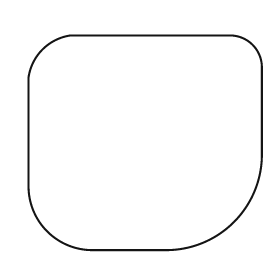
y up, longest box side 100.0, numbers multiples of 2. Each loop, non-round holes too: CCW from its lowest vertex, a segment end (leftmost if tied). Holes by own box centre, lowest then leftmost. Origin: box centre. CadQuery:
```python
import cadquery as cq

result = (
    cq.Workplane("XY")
    .moveTo(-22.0, -46.0)
    .lineTo(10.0, -46.0)
    .threePointArc((38.0, -34.0), (50.0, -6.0))
    .lineTo(50.0, 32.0)
    .threePointArc((46.0, 42.0), (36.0, 46.0))
    .lineTo(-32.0, 46.0)
    .threePointArc((-44.0, 40.0), (-50.0, 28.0))
    .lineTo(-50.0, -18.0)
    .threePointArc((-42.0, -38.0), (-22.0, -46.0))
    .close()
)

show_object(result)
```